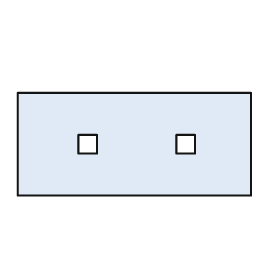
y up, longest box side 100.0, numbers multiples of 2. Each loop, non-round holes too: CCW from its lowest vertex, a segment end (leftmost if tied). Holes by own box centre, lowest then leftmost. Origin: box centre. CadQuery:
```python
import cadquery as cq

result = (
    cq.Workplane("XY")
    .moveTo(-50.0, -22.0)
    .lineTo(50.0, -22.0)
    .lineTo(50.0, 22.0)
    .lineTo(-50.0, 22.0)
    .close()
    .moveTo(-24.0, -4.0)
    .lineTo(-16.0, -4.0)
    .lineTo(-16.0, 4.0)
    .lineTo(-24.0, 4.0)
    .close()
    .moveTo(18.0, -4.0)
    .lineTo(26.0, -4.0)
    .lineTo(26.0, 4.0)
    .lineTo(18.0, 4.0)
    .close()
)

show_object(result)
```